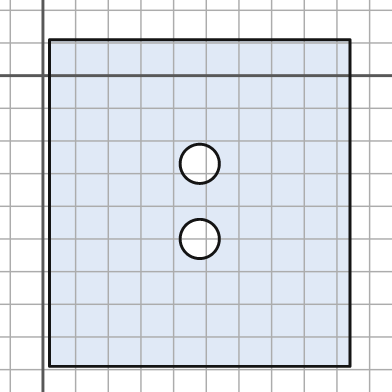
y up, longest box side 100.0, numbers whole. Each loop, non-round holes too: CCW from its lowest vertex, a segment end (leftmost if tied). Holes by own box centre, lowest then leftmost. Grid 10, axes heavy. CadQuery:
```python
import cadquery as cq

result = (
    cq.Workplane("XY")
    .moveTo(2.0, -89.0)
    .lineTo(94.0, -89.0)
    .lineTo(94.0, 11.0)
    .lineTo(2.0, 11.0)
    .close()
    .moveTo(48.0, -50.0)
    .circle(6.0)
    .moveTo(48.0, -27.0)
    .circle(6.0)
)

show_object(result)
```